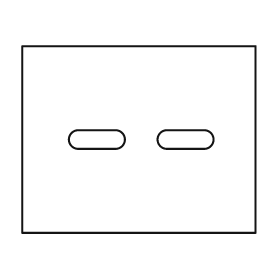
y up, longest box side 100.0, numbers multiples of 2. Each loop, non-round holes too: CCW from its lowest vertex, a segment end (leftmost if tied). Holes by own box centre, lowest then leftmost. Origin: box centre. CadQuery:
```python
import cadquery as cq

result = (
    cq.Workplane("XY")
    .moveTo(-50.0, -40.0)
    .lineTo(50.0, -40.0)
    .lineTo(50.0, 40.0)
    .lineTo(-50.0, 40.0)
    .close()
    .moveTo(-26.0, -4.0)
    .lineTo(-10.0, -4.0)
    .threePointArc((-6.0, 0.0), (-10.0, 4.0))
    .lineTo(-26.0, 4.0)
    .threePointArc((-30.0, 0.0), (-26.0, -4.0))
    .close()
    .moveTo(12.0, -4.0)
    .lineTo(28.0, -4.0)
    .threePointArc((32.0, 0.0), (28.0, 4.0))
    .lineTo(12.0, 4.0)
    .threePointArc((8.0, 0.0), (12.0, -4.0))
    .close()
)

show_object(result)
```